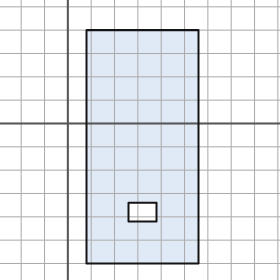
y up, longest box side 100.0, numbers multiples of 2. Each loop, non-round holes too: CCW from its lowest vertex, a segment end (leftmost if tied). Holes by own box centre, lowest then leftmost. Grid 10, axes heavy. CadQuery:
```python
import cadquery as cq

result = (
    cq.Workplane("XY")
    .moveTo(8.0, -60.0)
    .lineTo(56.0, -60.0)
    .lineTo(56.0, 40.0)
    .lineTo(8.0, 40.0)
    .close()
    .moveTo(26.0, -42.0)
    .lineTo(38.0, -42.0)
    .lineTo(38.0, -34.0)
    .lineTo(26.0, -34.0)
    .close()
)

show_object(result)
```